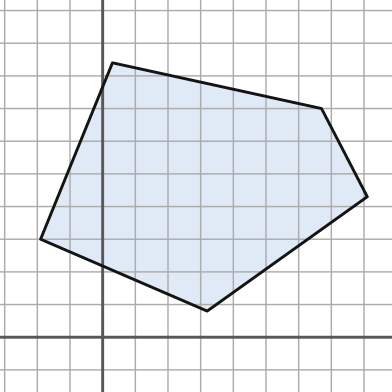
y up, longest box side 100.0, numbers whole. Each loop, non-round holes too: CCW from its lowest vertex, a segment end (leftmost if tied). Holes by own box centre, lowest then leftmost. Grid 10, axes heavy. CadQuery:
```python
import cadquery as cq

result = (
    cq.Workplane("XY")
    .moveTo(32.0, 8.0)
    .lineTo(81.0, 43.0)
    .lineTo(67.0, 70.0)
    .lineTo(3.0, 84.0)
    .lineTo(-19.0, 30.0)
    .close()
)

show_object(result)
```